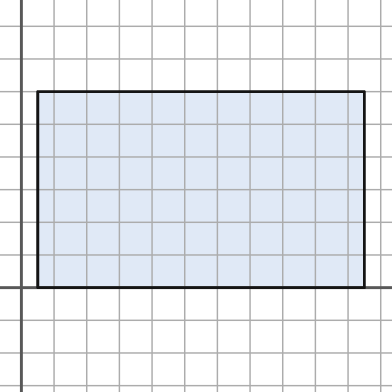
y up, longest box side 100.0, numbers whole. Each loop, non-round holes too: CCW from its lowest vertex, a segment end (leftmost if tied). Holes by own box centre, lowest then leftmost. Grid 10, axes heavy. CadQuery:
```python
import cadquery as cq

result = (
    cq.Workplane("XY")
    .moveTo(5.0, 0.0)
    .lineTo(105.0, 0.0)
    .lineTo(105.0, 60.0)
    .lineTo(5.0, 60.0)
    .close()
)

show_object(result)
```